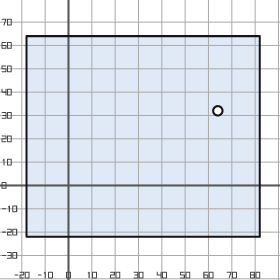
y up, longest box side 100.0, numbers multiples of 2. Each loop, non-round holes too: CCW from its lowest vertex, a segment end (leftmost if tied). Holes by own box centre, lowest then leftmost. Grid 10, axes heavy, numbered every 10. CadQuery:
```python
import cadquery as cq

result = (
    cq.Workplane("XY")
    .moveTo(-18.0, -22.0)
    .lineTo(82.0, -22.0)
    .lineTo(82.0, 64.0)
    .lineTo(-18.0, 64.0)
    .close()
    .moveTo(64.0, 32.0)
    .circle(2.0)
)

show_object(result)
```